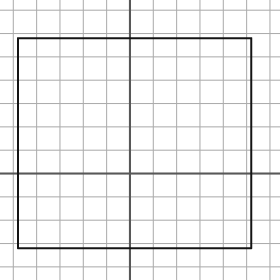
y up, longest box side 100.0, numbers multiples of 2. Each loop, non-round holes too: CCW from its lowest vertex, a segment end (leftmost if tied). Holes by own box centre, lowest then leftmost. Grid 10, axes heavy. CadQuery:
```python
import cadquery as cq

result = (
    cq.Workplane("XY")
    .moveTo(-48.0, -32.0)
    .lineTo(52.0, -32.0)
    .lineTo(52.0, 58.0)
    .lineTo(-48.0, 58.0)
    .close()
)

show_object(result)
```